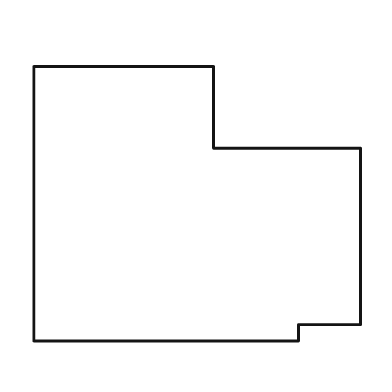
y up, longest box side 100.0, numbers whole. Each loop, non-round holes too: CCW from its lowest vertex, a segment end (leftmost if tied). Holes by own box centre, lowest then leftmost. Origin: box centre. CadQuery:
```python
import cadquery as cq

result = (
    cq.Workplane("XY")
    .moveTo(-50.0, -42.0)
    .lineTo(31.0, -42.0)
    .lineTo(31.0, -37.0)
    .lineTo(50.0, -37.0)
    .lineTo(50.0, 17.0)
    .lineTo(5.0, 17.0)
    .lineTo(5.0, 42.0)
    .lineTo(-50.0, 42.0)
    .close()
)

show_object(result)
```